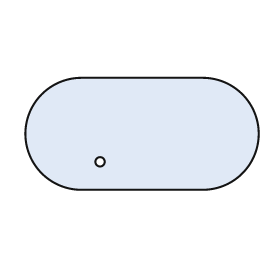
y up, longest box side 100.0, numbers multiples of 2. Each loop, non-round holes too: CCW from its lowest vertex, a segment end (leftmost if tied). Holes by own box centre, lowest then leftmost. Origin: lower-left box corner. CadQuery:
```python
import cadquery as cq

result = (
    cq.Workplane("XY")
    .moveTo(24.0, 0.0)
    .lineTo(76.0, 0.0)
    .threePointArc((100.0, 24.0), (76.0, 48.0))
    .lineTo(24.0, 48.0)
    .threePointArc((0.0, 24.0), (24.0, 0.0))
    .close()
    .moveTo(32.0, 12.0)
    .circle(2.0)
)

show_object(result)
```